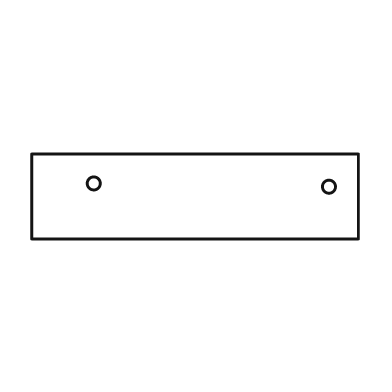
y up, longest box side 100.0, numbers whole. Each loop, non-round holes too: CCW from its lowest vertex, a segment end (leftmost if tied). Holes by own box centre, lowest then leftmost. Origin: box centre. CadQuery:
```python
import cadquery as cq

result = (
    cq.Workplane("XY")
    .moveTo(-50.0, -13.0)
    .lineTo(50.0, -13.0)
    .lineTo(50.0, 13.0)
    .lineTo(-50.0, 13.0)
    .close()
    .moveTo(41.0, 3.0)
    .circle(2.0)
    .moveTo(-31.0, 4.0)
    .circle(2.0)
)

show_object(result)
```